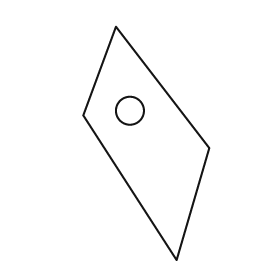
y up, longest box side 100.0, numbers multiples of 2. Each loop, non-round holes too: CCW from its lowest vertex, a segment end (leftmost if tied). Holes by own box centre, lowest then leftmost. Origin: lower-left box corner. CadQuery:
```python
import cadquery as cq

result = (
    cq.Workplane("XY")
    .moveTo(40.0, 0.0)
    .lineTo(54.0, 48.0)
    .lineTo(14.0, 100.0)
    .lineTo(0.0, 62.0)
    .close()
    .moveTo(20.0, 64.0)
    .circle(6.0)
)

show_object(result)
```